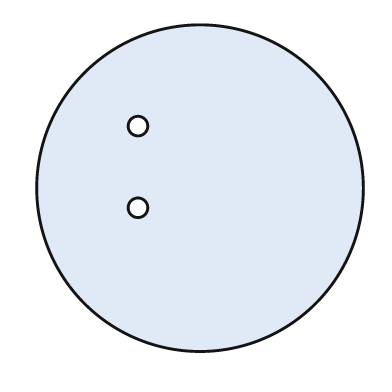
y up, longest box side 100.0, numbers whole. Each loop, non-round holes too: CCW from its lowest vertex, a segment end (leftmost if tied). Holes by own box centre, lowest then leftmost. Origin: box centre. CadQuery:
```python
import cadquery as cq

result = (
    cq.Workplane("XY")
    .moveTo(0.0, 0.0)
    .circle(50.0)
    .moveTo(-19.0, -6.0)
    .circle(3.0)
    .moveTo(-19.0, 19.0)
    .circle(3.0)
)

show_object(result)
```